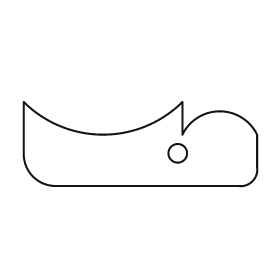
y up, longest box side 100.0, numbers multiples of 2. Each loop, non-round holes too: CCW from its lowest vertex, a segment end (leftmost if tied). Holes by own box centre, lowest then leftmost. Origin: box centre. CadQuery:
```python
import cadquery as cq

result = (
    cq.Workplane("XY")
    .moveTo(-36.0, -18.0)
    .lineTo(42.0, -18.0)
    .threePointArc((48.0, -16.0), (50.0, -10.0))
    .lineTo(50.0, 4.0)
    .threePointArc((34.0, 14.0), (18.0, 4.0))
    .lineTo(18.0, 18.0)
    .threePointArc((-16.0, 4.0), (-50.0, 18.0))
    .lineTo(-50.0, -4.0)
    .threePointArc((-46.0, -14.0), (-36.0, -18.0))
    .close()
    .moveTo(16.0, -4.0)
    .circle(4.0)
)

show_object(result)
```